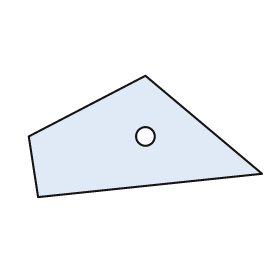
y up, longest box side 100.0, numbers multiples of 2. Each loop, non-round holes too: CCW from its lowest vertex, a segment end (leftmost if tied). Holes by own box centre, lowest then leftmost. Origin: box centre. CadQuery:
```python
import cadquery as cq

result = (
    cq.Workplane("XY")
    .moveTo(-46.0, -26.0)
    .lineTo(50.0, -16.0)
    .lineTo(0.0, 26.0)
    .lineTo(-50.0, 0.0)
    .close()
    .moveTo(0.0, 0.0)
    .circle(4.0)
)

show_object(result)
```